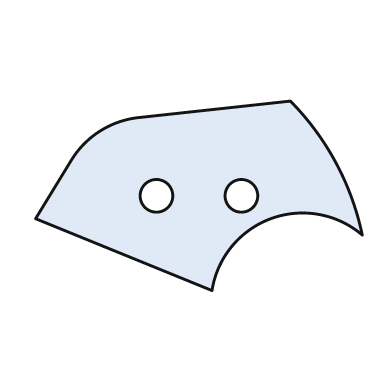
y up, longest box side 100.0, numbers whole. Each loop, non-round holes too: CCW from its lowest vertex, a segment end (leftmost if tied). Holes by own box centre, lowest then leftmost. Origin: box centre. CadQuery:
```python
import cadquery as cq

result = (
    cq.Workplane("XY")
    .moveTo(4.0, -29.0)
    .threePointArc((22.0, -7.0), (50.0, -12.0))
    .threePointArc((42.0, 10.0), (28.0, 29.0))
    .lineTo(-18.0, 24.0)
    .threePointArc((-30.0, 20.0), (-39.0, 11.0))
    .lineTo(-50.0, -7.0)
    .close()
    .moveTo(-13.0, 0.0)
    .circle(5.0)
    .moveTo(13.0, 0.0)
    .circle(5.0)
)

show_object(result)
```